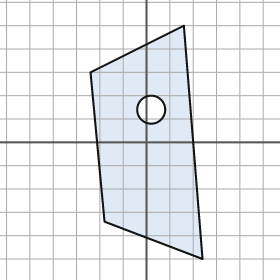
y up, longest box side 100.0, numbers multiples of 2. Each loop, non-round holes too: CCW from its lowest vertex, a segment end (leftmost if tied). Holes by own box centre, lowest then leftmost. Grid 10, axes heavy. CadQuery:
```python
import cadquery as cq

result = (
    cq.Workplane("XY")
    .moveTo(24.0, -50.0)
    .lineTo(16.0, 50.0)
    .lineTo(-24.0, 30.0)
    .lineTo(-18.0, -34.0)
    .close()
    .moveTo(2.0, 14.0)
    .circle(6.0)
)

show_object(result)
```